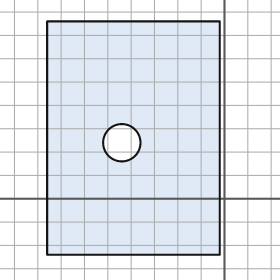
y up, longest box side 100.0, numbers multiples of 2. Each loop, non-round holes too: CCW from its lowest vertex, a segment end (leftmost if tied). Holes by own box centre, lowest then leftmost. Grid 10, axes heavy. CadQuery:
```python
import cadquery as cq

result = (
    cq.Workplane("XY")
    .moveTo(-76.0, -24.0)
    .lineTo(-2.0, -24.0)
    .lineTo(-2.0, 76.0)
    .lineTo(-76.0, 76.0)
    .close()
    .moveTo(-44.0, 24.0)
    .circle(8.0)
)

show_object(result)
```